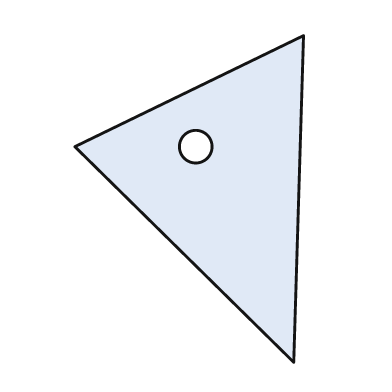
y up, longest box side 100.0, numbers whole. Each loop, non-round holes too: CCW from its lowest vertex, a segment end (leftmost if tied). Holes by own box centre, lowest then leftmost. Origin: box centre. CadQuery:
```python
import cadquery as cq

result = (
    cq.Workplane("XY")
    .moveTo(32.0, -50.0)
    .lineTo(35.0, 50.0)
    .lineTo(-35.0, 16.0)
    .close()
    .moveTo(2.0, 16.0)
    .circle(5.0)
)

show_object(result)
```